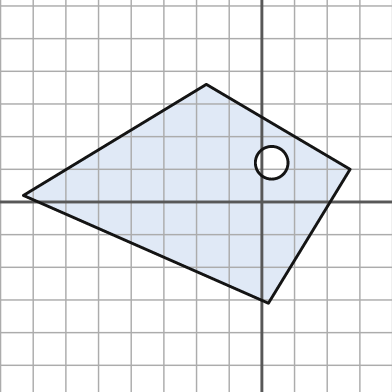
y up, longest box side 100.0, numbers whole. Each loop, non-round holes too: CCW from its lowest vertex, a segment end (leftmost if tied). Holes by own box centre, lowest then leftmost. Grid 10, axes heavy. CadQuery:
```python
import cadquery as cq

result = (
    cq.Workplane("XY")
    .moveTo(2.0, -31.0)
    .lineTo(27.0, 10.0)
    .lineTo(-17.0, 36.0)
    .lineTo(-73.0, 2.0)
    .close()
    .moveTo(3.0, 12.0)
    .circle(5.0)
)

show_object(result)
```